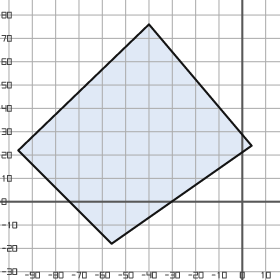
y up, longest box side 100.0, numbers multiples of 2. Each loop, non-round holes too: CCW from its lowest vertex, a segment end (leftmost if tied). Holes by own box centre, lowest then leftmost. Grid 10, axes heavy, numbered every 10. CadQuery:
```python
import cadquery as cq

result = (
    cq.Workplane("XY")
    .moveTo(-56.0, -18.0)
    .lineTo(4.0, 24.0)
    .lineTo(-40.0, 76.0)
    .lineTo(-96.0, 22.0)
    .close()
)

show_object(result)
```